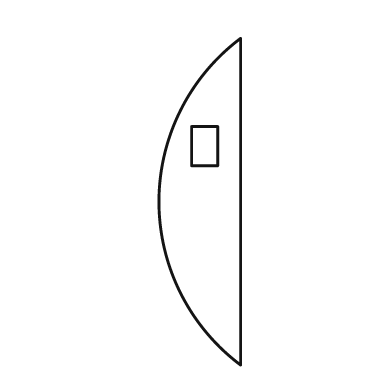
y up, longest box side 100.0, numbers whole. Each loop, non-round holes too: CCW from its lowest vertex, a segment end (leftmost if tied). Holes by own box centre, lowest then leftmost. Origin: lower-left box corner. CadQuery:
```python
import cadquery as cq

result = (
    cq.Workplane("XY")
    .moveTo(25.0, 0.0)
    .lineTo(25.0, 100.0)
    .threePointArc((0.0, 50.0), (25.0, 0.0))
    .close()
    .moveTo(10.0, 61.0)
    .lineTo(18.0, 61.0)
    .lineTo(18.0, 73.0)
    .lineTo(10.0, 73.0)
    .close()
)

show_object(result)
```